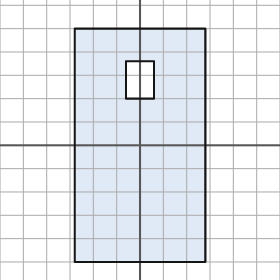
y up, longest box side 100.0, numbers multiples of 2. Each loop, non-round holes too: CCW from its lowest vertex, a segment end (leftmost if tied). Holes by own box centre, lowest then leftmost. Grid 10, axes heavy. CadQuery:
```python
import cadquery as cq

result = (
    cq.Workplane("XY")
    .moveTo(-28.0, -50.0)
    .lineTo(28.0, -50.0)
    .lineTo(28.0, 50.0)
    .lineTo(-28.0, 50.0)
    .close()
    .moveTo(-6.0, 20.0)
    .lineTo(6.0, 20.0)
    .lineTo(6.0, 36.0)
    .lineTo(-6.0, 36.0)
    .close()
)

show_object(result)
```